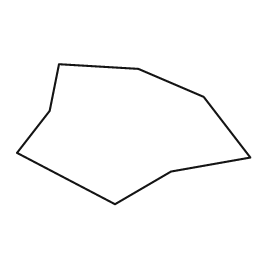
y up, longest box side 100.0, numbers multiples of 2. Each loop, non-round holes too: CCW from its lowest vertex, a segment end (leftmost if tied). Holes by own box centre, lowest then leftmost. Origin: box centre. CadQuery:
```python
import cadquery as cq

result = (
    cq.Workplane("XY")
    .moveTo(-8.0, -30.0)
    .lineTo(16.0, -16.0)
    .lineTo(50.0, -10.0)
    .lineTo(30.0, 16.0)
    .lineTo(2.0, 28.0)
    .lineTo(-32.0, 30.0)
    .lineTo(-36.0, 10.0)
    .lineTo(-50.0, -8.0)
    .close()
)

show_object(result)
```